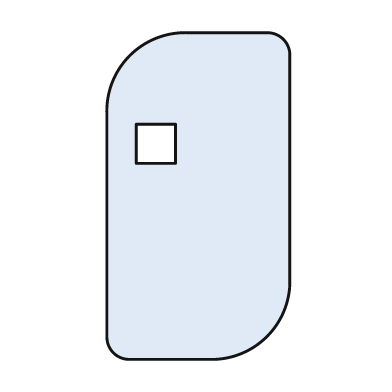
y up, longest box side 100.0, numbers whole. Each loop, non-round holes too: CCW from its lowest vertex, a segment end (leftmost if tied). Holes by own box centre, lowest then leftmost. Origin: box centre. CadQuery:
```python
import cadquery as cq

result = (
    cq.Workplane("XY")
    .moveTo(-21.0, -50.0)
    .lineTo(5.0, -50.0)
    .threePointArc((21.0, -43.0), (28.0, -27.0))
    .lineTo(28.0, 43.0)
    .threePointArc((26.0, 48.0), (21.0, 50.0))
    .lineTo(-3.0, 50.0)
    .threePointArc((-21.0, 43.0), (-28.0, 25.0))
    .lineTo(-28.0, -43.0)
    .threePointArc((-26.0, -48.0), (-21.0, -50.0))
    .close()
    .moveTo(-19.0, 10.0)
    .lineTo(-7.0, 10.0)
    .lineTo(-7.0, 22.0)
    .lineTo(-19.0, 22.0)
    .close()
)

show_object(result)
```